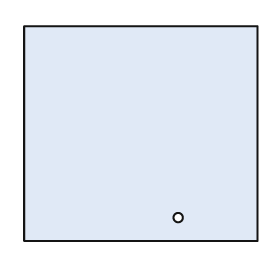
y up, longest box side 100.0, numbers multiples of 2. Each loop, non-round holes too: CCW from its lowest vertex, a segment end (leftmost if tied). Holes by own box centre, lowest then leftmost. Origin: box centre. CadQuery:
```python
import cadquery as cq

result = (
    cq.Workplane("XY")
    .moveTo(-50.0, -46.0)
    .lineTo(50.0, -46.0)
    .lineTo(50.0, 46.0)
    .lineTo(-50.0, 46.0)
    .close()
    .moveTo(16.0, -36.0)
    .circle(2.0)
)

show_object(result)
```